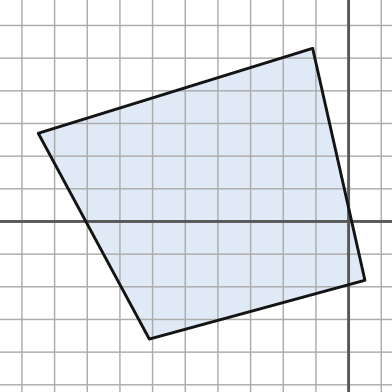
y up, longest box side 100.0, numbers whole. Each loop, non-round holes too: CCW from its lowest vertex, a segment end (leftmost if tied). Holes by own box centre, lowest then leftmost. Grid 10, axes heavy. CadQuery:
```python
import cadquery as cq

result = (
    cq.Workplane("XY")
    .moveTo(-61.0, -36.0)
    .lineTo(5.0, -18.0)
    .lineTo(-11.0, 53.0)
    .lineTo(-95.0, 27.0)
    .close()
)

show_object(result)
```